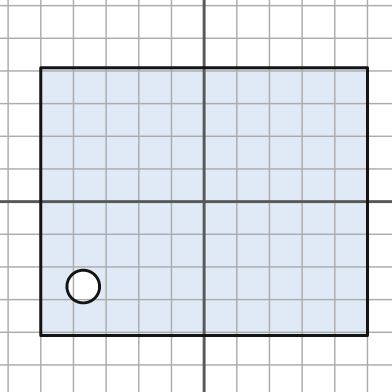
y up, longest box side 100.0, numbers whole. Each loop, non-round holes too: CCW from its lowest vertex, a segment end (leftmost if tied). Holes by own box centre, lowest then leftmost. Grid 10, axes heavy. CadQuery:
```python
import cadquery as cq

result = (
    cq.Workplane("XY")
    .moveTo(-50.0, -41.0)
    .lineTo(50.0, -41.0)
    .lineTo(50.0, 41.0)
    .lineTo(-50.0, 41.0)
    .close()
    .moveTo(-37.0, -26.0)
    .circle(5.0)
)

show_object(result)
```